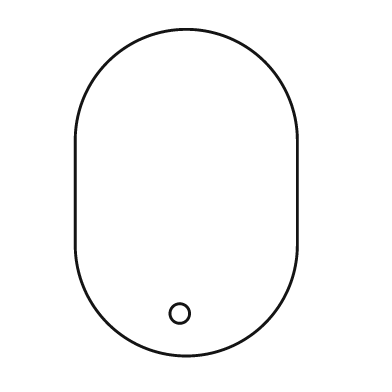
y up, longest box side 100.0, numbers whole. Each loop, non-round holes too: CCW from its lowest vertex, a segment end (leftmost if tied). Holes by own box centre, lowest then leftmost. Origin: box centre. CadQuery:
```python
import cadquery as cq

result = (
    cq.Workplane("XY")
    .moveTo(-34.0, -16.0)
    .threePointArc((0.0, -50.0), (34.0, -16.0))
    .lineTo(34.0, 16.0)
    .threePointArc((0.0, 50.0), (-34.0, 16.0))
    .close()
    .moveTo(-2.0, -37.0)
    .circle(3.0)
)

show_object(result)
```